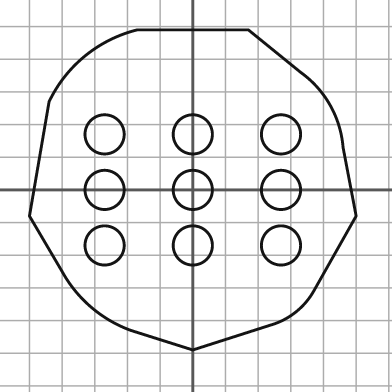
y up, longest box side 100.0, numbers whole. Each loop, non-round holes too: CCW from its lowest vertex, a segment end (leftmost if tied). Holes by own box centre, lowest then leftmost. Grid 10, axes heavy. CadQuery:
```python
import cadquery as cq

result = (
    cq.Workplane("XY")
    .moveTo(0.0, -49.0)
    .lineTo(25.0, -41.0)
    .threePointArc((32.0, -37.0), (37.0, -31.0))
    .lineTo(50.0, -8.0)
    .lineTo(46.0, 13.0)
    .threePointArc((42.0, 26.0), (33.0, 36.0))
    .lineTo(17.0, 49.0)
    .lineTo(-17.0, 49.0)
    .threePointArc((-33.0, 41.0), (-44.0, 27.0))
    .lineTo(-50.0, -8.0)
    .lineTo(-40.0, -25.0)
    .threePointArc((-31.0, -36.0), (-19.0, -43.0))
    .close()
    .moveTo(-27.0, -17.0)
    .circle(6.0)
    .moveTo(0.0, -17.0)
    .circle(6.0)
    .moveTo(27.0, -17.0)
    .circle(6.0)
    .moveTo(-27.0, 0.0)
    .circle(6.0)
    .moveTo(0.0, 0.0)
    .circle(6.0)
    .moveTo(27.0, 0.0)
    .circle(6.0)
    .moveTo(-27.0, 17.0)
    .circle(6.0)
    .moveTo(0.0, 17.0)
    .circle(6.0)
    .moveTo(27.0, 17.0)
    .circle(6.0)
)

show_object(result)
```